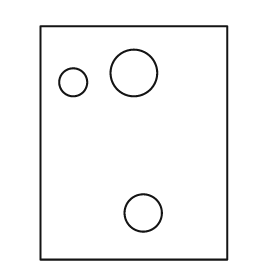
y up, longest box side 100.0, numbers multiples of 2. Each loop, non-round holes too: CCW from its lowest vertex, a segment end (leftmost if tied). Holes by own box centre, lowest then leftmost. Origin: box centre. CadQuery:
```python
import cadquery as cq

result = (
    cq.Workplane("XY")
    .moveTo(-40.0, -50.0)
    .lineTo(40.0, -50.0)
    .lineTo(40.0, 50.0)
    .lineTo(-40.0, 50.0)
    .close()
    .moveTo(4.0, -30.0)
    .circle(8.0)
    .moveTo(-26.0, 26.0)
    .circle(6.0)
    .moveTo(0.0, 30.0)
    .circle(10.0)
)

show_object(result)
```